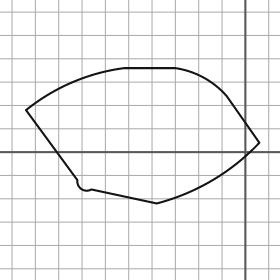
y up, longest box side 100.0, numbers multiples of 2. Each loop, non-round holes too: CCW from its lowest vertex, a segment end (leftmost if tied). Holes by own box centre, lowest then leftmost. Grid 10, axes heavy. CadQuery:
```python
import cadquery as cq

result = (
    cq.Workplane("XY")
    .moveTo(-38.0, -22.0)
    .threePointArc((-14.0, -12.0), (6.0, 4.0))
    .lineTo(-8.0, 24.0)
    .threePointArc((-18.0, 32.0), (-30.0, 36.0))
    .lineTo(-52.0, 36.0)
    .threePointArc((-74.0, 30.0), (-94.0, 18.0))
    .lineTo(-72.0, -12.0)
    .threePointArc((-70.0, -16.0), (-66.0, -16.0))
    .close()
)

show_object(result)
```